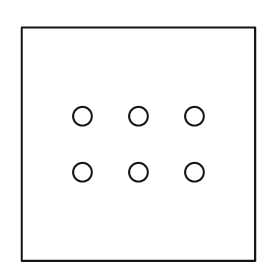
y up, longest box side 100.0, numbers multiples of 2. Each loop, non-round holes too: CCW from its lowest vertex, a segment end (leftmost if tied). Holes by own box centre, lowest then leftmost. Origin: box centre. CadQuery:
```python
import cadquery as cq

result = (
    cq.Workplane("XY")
    .moveTo(-50.0, -50.0)
    .lineTo(50.0, -50.0)
    .lineTo(50.0, 50.0)
    .lineTo(-50.0, 50.0)
    .close()
    .moveTo(-24.0, -12.0)
    .circle(4.0)
    .moveTo(0.0, -12.0)
    .circle(4.0)
    .moveTo(24.0, -12.0)
    .circle(4.0)
    .moveTo(-24.0, 12.0)
    .circle(4.0)
    .moveTo(0.0, 12.0)
    .circle(4.0)
    .moveTo(24.0, 12.0)
    .circle(4.0)
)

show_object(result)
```